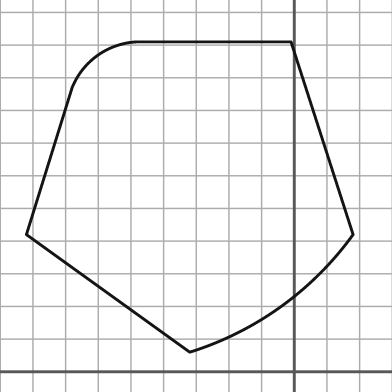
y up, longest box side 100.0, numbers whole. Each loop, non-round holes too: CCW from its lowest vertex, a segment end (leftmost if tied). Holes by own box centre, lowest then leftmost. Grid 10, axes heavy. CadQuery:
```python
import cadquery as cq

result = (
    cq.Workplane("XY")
    .moveTo(-32.0, 6.0)
    .threePointArc((-4.0, 20.0), (18.0, 42.0))
    .lineTo(-1.0, 101.0)
    .lineTo(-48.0, 101.0)
    .threePointArc((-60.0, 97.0), (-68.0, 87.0))
    .lineTo(-82.0, 42.0)
    .close()
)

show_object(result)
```